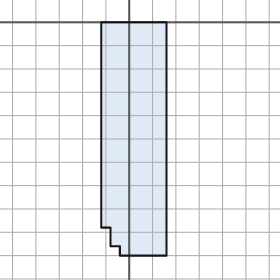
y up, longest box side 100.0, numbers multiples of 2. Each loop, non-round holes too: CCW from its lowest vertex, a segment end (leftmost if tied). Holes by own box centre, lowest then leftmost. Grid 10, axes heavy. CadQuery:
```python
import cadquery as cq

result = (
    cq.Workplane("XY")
    .moveTo(-4.0, -100.0)
    .lineTo(16.0, -100.0)
    .lineTo(16.0, 0.0)
    .lineTo(-12.0, 0.0)
    .lineTo(-12.0, -88.0)
    .lineTo(-8.0, -88.0)
    .lineTo(-8.0, -96.0)
    .lineTo(-4.0, -96.0)
    .close()
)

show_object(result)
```